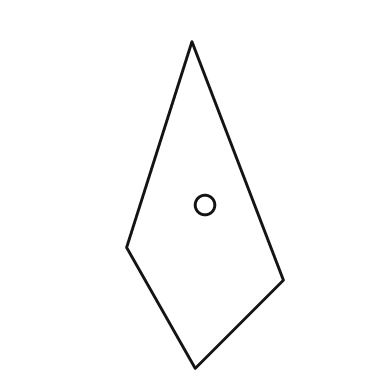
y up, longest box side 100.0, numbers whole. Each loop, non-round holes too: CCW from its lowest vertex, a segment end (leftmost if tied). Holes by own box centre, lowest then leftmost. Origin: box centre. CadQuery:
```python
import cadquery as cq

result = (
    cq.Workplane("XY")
    .moveTo(-3.0, -50.0)
    .lineTo(24.0, -23.0)
    .lineTo(-4.0, 50.0)
    .lineTo(-24.0, -13.0)
    .close()
    .moveTo(0.0, 0.0)
    .circle(3.0)
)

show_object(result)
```